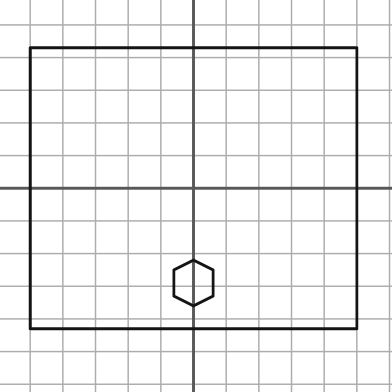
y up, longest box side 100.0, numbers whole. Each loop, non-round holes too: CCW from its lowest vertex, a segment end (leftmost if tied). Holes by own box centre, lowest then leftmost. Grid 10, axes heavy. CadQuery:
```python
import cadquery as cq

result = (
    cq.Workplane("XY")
    .moveTo(-50.0, -43.0)
    .lineTo(50.0, -43.0)
    .lineTo(50.0, 43.0)
    .lineTo(-50.0, 43.0)
    .close()
    .moveTo(0.0, -36.0)
    .lineTo(6.0, -33.0)
    .lineTo(6.0, -25.0)
    .lineTo(0.0, -22.0)
    .lineTo(-6.0, -25.0)
    .lineTo(-6.0, -33.0)
    .close()
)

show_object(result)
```